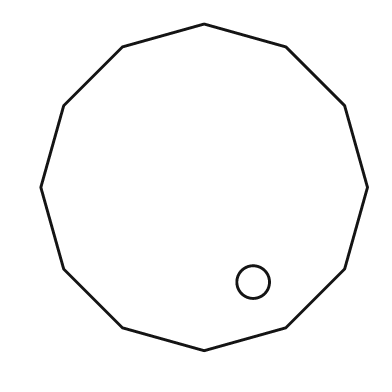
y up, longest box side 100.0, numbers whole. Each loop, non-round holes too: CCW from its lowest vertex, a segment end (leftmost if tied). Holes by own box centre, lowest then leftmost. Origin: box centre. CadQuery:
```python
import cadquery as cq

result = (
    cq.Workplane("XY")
    .moveTo(0.0, -50.0)
    .lineTo(25.0, -43.0)
    .lineTo(43.0, -25.0)
    .lineTo(50.0, 0.0)
    .lineTo(43.0, 25.0)
    .lineTo(25.0, 43.0)
    .lineTo(0.0, 50.0)
    .lineTo(-25.0, 43.0)
    .lineTo(-43.0, 25.0)
    .lineTo(-50.0, 0.0)
    .lineTo(-43.0, -25.0)
    .lineTo(-25.0, -43.0)
    .close()
    .moveTo(15.0, -29.0)
    .circle(5.0)
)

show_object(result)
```